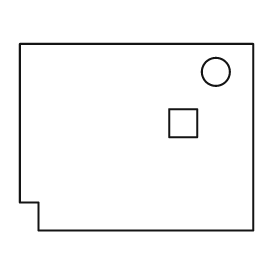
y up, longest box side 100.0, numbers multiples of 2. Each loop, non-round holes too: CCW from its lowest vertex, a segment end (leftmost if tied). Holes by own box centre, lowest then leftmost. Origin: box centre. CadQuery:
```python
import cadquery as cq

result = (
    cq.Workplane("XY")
    .moveTo(-42.0, -40.0)
    .lineTo(50.0, -40.0)
    .lineTo(50.0, 40.0)
    .lineTo(-50.0, 40.0)
    .lineTo(-50.0, -28.0)
    .lineTo(-42.0, -28.0)
    .close()
    .moveTo(14.0, 0.0)
    .lineTo(26.0, 0.0)
    .lineTo(26.0, 12.0)
    .lineTo(14.0, 12.0)
    .close()
    .moveTo(34.0, 28.0)
    .circle(6.0)
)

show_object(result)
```